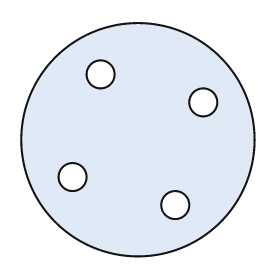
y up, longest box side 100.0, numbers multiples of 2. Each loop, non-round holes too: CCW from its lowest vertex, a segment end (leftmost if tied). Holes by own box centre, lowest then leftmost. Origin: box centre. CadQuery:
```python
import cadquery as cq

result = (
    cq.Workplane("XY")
    .moveTo(0.0, 0.0)
    .circle(50.0)
    .moveTo(16.0, -28.0)
    .circle(6.0)
    .moveTo(-28.0, -16.0)
    .circle(6.0)
    .moveTo(28.0, 16.0)
    .circle(6.0)
    .moveTo(-16.0, 28.0)
    .circle(6.0)
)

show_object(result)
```